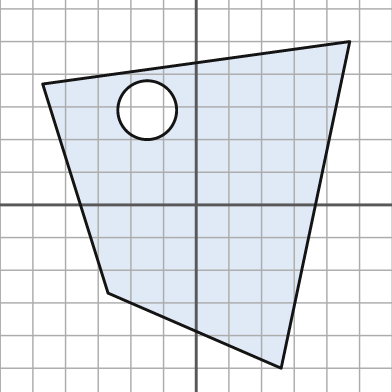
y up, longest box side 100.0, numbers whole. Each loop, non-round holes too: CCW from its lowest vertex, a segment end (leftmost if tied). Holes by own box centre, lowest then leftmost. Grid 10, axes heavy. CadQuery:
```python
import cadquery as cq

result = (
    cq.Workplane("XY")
    .moveTo(26.0, -50.0)
    .lineTo(47.0, 50.0)
    .lineTo(-47.0, 37.0)
    .lineTo(-27.0, -27.0)
    .close()
    .moveTo(-15.0, 29.0)
    .circle(9.0)
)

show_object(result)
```